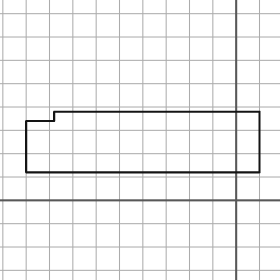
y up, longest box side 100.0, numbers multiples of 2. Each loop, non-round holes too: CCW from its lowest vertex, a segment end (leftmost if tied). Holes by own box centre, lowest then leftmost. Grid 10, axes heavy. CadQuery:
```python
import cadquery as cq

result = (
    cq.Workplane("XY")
    .moveTo(-90.0, 12.0)
    .lineTo(10.0, 12.0)
    .lineTo(10.0, 38.0)
    .lineTo(-78.0, 38.0)
    .lineTo(-78.0, 34.0)
    .lineTo(-90.0, 34.0)
    .close()
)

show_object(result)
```